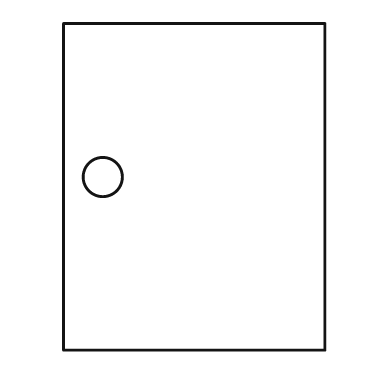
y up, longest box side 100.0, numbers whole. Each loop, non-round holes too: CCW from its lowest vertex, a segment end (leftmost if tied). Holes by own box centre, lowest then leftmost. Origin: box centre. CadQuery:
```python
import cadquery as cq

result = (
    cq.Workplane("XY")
    .moveTo(-40.0, -50.0)
    .lineTo(40.0, -50.0)
    .lineTo(40.0, 50.0)
    .lineTo(-40.0, 50.0)
    .close()
    .moveTo(-28.0, 3.0)
    .circle(6.0)
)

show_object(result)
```